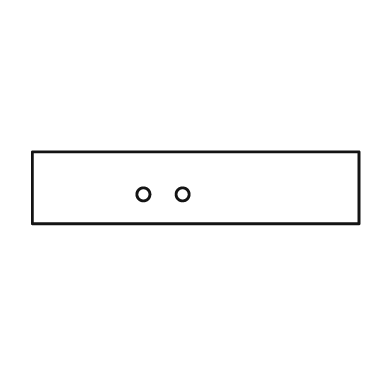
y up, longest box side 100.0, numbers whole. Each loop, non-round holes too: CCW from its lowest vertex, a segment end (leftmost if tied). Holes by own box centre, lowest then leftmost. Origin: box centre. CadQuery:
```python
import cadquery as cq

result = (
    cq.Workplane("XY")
    .moveTo(-50.0, -11.0)
    .lineTo(50.0, -11.0)
    .lineTo(50.0, 11.0)
    .lineTo(-50.0, 11.0)
    .close()
    .moveTo(-16.0, -2.0)
    .circle(2.0)
    .moveTo(-4.0, -2.0)
    .circle(2.0)
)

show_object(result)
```